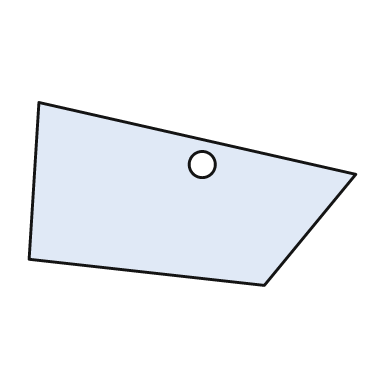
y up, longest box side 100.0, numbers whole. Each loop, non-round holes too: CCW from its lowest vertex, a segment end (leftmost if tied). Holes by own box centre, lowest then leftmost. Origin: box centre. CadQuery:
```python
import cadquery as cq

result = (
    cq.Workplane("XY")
    .moveTo(22.0, -28.0)
    .lineTo(50.0, 6.0)
    .lineTo(-47.0, 28.0)
    .lineTo(-50.0, -20.0)
    .close()
    .moveTo(3.0, 9.0)
    .circle(4.0)
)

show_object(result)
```